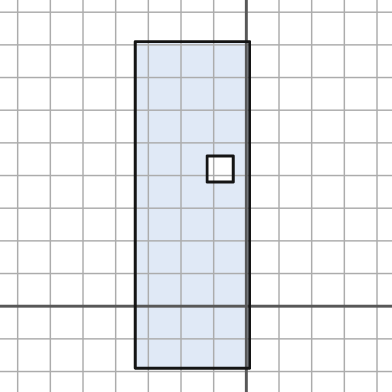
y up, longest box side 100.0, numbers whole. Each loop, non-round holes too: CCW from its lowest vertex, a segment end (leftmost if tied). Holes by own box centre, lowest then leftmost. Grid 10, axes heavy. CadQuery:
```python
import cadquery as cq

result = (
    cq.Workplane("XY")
    .moveTo(-34.0, -19.0)
    .lineTo(1.0, -19.0)
    .lineTo(1.0, 81.0)
    .lineTo(-34.0, 81.0)
    .close()
    .moveTo(-12.0, 38.0)
    .lineTo(-4.0, 38.0)
    .lineTo(-4.0, 46.0)
    .lineTo(-12.0, 46.0)
    .close()
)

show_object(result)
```